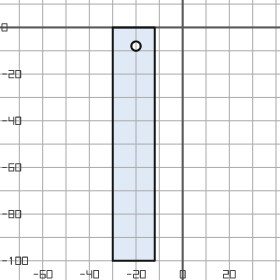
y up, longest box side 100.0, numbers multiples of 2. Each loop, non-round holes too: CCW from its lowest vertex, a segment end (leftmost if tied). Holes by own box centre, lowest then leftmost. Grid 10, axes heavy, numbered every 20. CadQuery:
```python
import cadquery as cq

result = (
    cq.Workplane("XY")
    .moveTo(-30.0, -100.0)
    .lineTo(-12.0, -100.0)
    .lineTo(-12.0, 0.0)
    .lineTo(-30.0, 0.0)
    .close()
    .moveTo(-20.0, -8.0)
    .circle(2.0)
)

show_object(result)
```